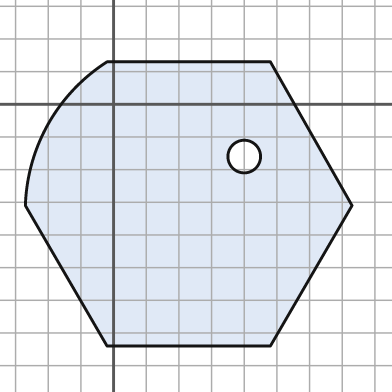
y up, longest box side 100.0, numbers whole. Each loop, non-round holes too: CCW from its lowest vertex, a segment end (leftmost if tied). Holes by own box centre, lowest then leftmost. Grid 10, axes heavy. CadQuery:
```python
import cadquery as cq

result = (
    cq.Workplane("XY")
    .moveTo(-2.0, -74.0)
    .lineTo(48.0, -74.0)
    .lineTo(73.0, -31.0)
    .lineTo(48.0, 13.0)
    .lineTo(-2.0, 13.0)
    .threePointArc((-20.0, -6.0), (-27.0, -31.0))
    .close()
    .moveTo(40.0, -16.0)
    .circle(5.0)
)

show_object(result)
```